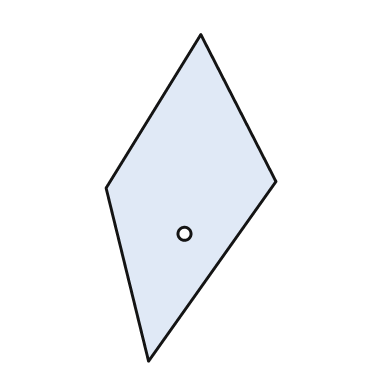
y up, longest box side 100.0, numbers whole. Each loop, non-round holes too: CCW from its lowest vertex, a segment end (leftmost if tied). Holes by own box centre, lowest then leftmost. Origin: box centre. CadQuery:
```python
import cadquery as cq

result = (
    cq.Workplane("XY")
    .moveTo(-13.0, -50.0)
    .lineTo(26.0, 5.0)
    .lineTo(3.0, 50.0)
    .lineTo(-26.0, 3.0)
    .close()
    .moveTo(-2.0, -11.0)
    .circle(2.0)
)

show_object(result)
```